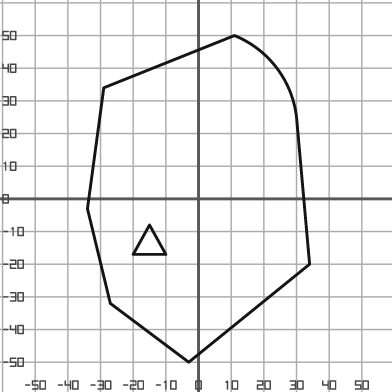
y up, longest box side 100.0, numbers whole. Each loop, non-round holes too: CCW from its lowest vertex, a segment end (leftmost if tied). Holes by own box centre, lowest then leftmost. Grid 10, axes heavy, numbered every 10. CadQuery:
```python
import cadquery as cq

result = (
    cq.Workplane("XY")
    .moveTo(-3.0, -50.0)
    .lineTo(34.0, -20.0)
    .lineTo(30.0, 25.0)
    .threePointArc((24.0, 40.0), (11.0, 50.0))
    .lineTo(-29.0, 34.0)
    .lineTo(-34.0, -3.0)
    .lineTo(-27.0, -32.0)
    .close()
    .moveTo(-20.0, -17.0)
    .lineTo(-10.0, -17.0)
    .lineTo(-15.0, -8.0)
    .close()
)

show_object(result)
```